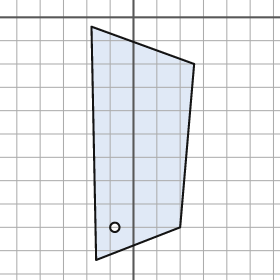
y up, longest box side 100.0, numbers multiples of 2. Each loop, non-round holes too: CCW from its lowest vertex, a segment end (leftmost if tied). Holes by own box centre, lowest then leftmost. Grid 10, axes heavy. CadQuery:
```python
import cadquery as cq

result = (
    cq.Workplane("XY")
    .moveTo(-16.0, -104.0)
    .lineTo(20.0, -90.0)
    .lineTo(26.0, -20.0)
    .lineTo(-18.0, -4.0)
    .close()
    .moveTo(-8.0, -90.0)
    .circle(2.0)
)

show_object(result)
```